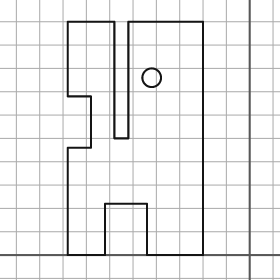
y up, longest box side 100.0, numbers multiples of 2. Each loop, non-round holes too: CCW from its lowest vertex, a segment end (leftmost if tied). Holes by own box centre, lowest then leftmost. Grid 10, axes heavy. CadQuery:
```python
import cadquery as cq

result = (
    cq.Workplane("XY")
    .moveTo(-78.0, 0.0)
    .lineTo(-62.0, 0.0)
    .lineTo(-62.0, 22.0)
    .lineTo(-44.0, 22.0)
    .lineTo(-44.0, 0.0)
    .lineTo(-20.0, 0.0)
    .lineTo(-20.0, 100.0)
    .lineTo(-52.0, 100.0)
    .lineTo(-52.0, 50.0)
    .lineTo(-58.0, 50.0)
    .lineTo(-58.0, 100.0)
    .lineTo(-78.0, 100.0)
    .lineTo(-78.0, 68.0)
    .lineTo(-68.0, 68.0)
    .lineTo(-68.0, 46.0)
    .lineTo(-78.0, 46.0)
    .close()
    .moveTo(-42.0, 76.0)
    .circle(4.0)
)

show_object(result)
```